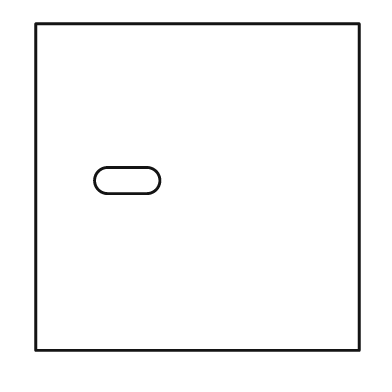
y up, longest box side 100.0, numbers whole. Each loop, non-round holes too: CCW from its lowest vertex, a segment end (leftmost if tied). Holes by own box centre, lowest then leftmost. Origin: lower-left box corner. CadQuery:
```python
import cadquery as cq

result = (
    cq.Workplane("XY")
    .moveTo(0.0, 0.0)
    .lineTo(99.0, 0.0)
    .lineTo(99.0, 100.0)
    .lineTo(0.0, 100.0)
    .close()
    .moveTo(22.0, 48.0)
    .lineTo(34.0, 48.0)
    .threePointArc((38.0, 52.0), (34.0, 56.0))
    .lineTo(22.0, 56.0)
    .threePointArc((18.0, 52.0), (22.0, 48.0))
    .close()
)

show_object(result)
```